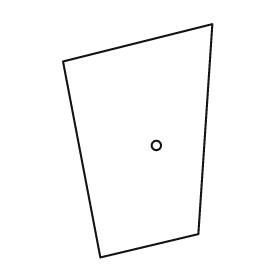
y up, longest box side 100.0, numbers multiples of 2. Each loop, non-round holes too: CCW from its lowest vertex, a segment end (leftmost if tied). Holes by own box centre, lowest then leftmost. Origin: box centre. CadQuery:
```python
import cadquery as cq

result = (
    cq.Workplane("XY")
    .moveTo(-16.0, -50.0)
    .lineTo(26.0, -40.0)
    .lineTo(32.0, 50.0)
    .lineTo(-32.0, 34.0)
    .close()
    .moveTo(8.0, -2.0)
    .circle(2.0)
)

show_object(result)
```